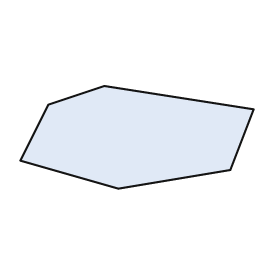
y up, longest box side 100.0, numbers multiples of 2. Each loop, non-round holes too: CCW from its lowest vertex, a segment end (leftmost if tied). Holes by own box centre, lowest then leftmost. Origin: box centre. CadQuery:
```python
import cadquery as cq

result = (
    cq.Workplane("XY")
    .moveTo(-8.0, -22.0)
    .lineTo(40.0, -14.0)
    .lineTo(50.0, 12.0)
    .lineTo(-14.0, 22.0)
    .lineTo(-38.0, 14.0)
    .lineTo(-50.0, -10.0)
    .close()
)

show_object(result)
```